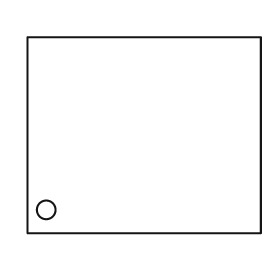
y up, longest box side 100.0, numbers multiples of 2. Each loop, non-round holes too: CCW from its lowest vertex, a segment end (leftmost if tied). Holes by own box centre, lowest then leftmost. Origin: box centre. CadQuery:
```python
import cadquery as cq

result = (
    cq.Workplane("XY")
    .moveTo(-50.0, -42.0)
    .lineTo(50.0, -42.0)
    .lineTo(50.0, 42.0)
    .lineTo(-50.0, 42.0)
    .close()
    .moveTo(-42.0, -32.0)
    .circle(4.0)
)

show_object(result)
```